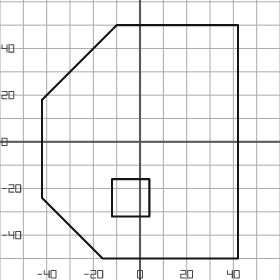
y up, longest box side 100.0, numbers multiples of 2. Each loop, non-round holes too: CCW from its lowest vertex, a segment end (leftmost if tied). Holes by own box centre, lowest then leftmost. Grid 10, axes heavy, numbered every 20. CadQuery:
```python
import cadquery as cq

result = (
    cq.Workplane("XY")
    .moveTo(-16.0, -50.0)
    .lineTo(42.0, -50.0)
    .lineTo(42.0, 50.0)
    .lineTo(-10.0, 50.0)
    .lineTo(-42.0, 18.0)
    .lineTo(-42.0, -24.0)
    .close()
    .moveTo(-12.0, -32.0)
    .lineTo(4.0, -32.0)
    .lineTo(4.0, -16.0)
    .lineTo(-12.0, -16.0)
    .close()
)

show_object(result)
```